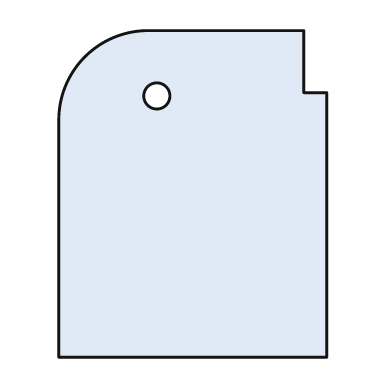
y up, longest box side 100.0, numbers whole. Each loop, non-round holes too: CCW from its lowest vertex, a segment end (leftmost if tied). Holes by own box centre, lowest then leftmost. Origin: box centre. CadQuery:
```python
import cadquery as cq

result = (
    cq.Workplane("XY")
    .moveTo(-41.0, -50.0)
    .lineTo(41.0, -50.0)
    .lineTo(41.0, 31.0)
    .lineTo(34.0, 31.0)
    .lineTo(34.0, 50.0)
    .lineTo(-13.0, 50.0)
    .threePointArc((-33.0, 42.0), (-41.0, 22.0))
    .close()
    .moveTo(-11.0, 30.0)
    .circle(4.0)
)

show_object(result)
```